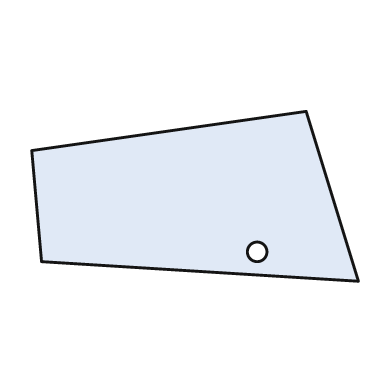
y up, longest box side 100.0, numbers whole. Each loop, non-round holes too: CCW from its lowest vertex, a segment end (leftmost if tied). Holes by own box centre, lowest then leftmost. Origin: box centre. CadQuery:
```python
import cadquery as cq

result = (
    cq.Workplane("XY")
    .moveTo(50.0, -26.0)
    .lineTo(34.0, 26.0)
    .lineTo(-50.0, 14.0)
    .lineTo(-47.0, -20.0)
    .close()
    .moveTo(19.0, -17.0)
    .circle(3.0)
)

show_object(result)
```